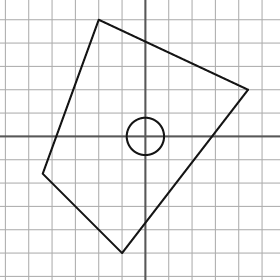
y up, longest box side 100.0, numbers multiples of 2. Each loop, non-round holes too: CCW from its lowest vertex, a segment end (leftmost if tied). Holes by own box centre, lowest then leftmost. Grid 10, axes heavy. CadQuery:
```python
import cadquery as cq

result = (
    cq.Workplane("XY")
    .moveTo(-10.0, -50.0)
    .lineTo(44.0, 20.0)
    .lineTo(-20.0, 50.0)
    .lineTo(-44.0, -16.0)
    .close()
    .moveTo(0.0, 0.0)
    .circle(8.0)
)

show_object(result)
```